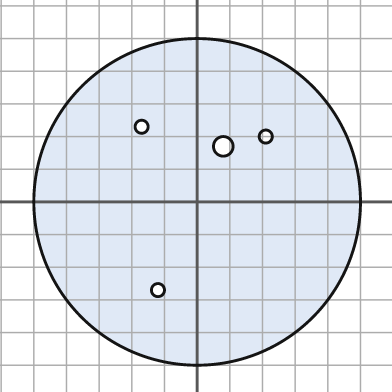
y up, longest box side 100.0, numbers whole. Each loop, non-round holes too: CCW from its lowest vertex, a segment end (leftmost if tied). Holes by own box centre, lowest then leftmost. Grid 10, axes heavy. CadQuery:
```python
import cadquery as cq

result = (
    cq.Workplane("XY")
    .moveTo(0.0, 0.0)
    .circle(50.0)
    .moveTo(-12.0, -27.0)
    .circle(2.0)
    .moveTo(8.0, 17.0)
    .circle(3.0)
    .moveTo(21.0, 20.0)
    .circle(2.0)
    .moveTo(-17.0, 23.0)
    .circle(2.0)
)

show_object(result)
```